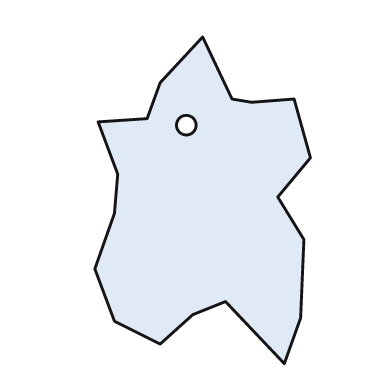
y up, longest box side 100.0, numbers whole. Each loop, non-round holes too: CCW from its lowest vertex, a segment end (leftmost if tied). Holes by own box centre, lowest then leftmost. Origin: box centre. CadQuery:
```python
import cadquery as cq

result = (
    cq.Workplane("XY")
    .moveTo(25.0, -50.0)
    .lineTo(30.0, -36.0)
    .lineTo(31.0, -12.0)
    .lineTo(23.0, 1.0)
    .lineTo(33.0, 13.0)
    .lineTo(28.0, 31.0)
    .lineTo(15.0, 30.0)
    .lineTo(9.0, 31.0)
    .lineTo(0.0, 50.0)
    .lineTo(-13.0, 36.0)
    .lineTo(-17.0, 25.0)
    .lineTo(-32.0, 24.0)
    .lineTo(-26.0, 8.0)
    .lineTo(-27.0, -4.0)
    .lineTo(-33.0, -21.0)
    .lineTo(-27.0, -37.0)
    .lineTo(-13.0, -44.0)
    .lineTo(-3.0, -35.0)
    .lineTo(7.0, -31.0)
    .close()
    .moveTo(-5.0, 23.0)
    .circle(3.0)
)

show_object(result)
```